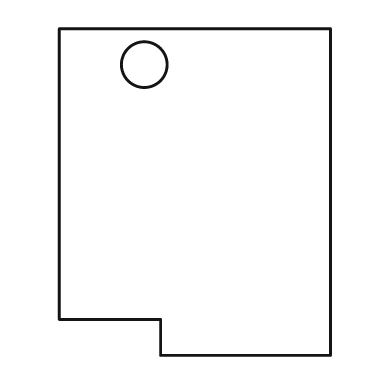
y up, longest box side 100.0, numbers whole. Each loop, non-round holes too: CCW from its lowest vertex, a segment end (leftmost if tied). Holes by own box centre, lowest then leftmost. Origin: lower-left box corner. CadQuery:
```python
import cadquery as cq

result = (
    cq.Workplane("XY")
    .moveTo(31.0, 0.0)
    .lineTo(83.0, 0.0)
    .lineTo(83.0, 100.0)
    .lineTo(0.0, 100.0)
    .lineTo(0.0, 11.0)
    .lineTo(31.0, 11.0)
    .close()
    .moveTo(26.0, 89.0)
    .circle(7.0)
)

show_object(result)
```